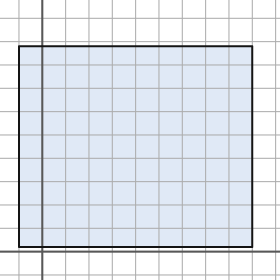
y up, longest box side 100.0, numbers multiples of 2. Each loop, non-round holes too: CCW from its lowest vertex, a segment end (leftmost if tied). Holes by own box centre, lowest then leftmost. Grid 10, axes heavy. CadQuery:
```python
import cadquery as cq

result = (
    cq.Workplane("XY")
    .moveTo(-10.0, 2.0)
    .lineTo(90.0, 2.0)
    .lineTo(90.0, 88.0)
    .lineTo(-10.0, 88.0)
    .close()
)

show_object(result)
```